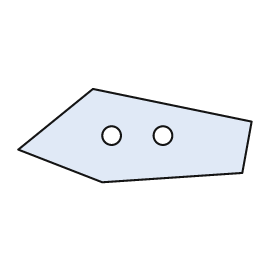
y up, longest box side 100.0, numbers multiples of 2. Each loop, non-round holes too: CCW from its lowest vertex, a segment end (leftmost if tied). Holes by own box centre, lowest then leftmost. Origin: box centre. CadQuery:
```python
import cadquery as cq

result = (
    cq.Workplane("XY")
    .moveTo(-14.0, -20.0)
    .lineTo(46.0, -16.0)
    .lineTo(50.0, 6.0)
    .lineTo(-18.0, 20.0)
    .lineTo(-50.0, -6.0)
    .close()
    .moveTo(-10.0, 0.0)
    .circle(4.0)
    .moveTo(12.0, 0.0)
    .circle(4.0)
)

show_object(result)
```